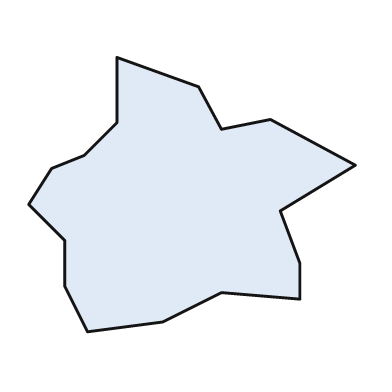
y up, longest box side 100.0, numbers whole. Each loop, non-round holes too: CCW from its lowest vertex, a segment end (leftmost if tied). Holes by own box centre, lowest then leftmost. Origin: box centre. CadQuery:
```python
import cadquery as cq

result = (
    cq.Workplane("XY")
    .moveTo(-32.0, -42.0)
    .lineTo(-9.0, -39.0)
    .lineTo(9.0, -30.0)
    .lineTo(33.0, -32.0)
    .lineTo(33.0, -21.0)
    .lineTo(27.0, -5.0)
    .lineTo(50.0, 9.0)
    .lineTo(24.0, 23.0)
    .lineTo(9.0, 20.0)
    .lineTo(2.0, 33.0)
    .lineTo(-23.0, 42.0)
    .lineTo(-23.0, 22.0)
    .lineTo(-33.0, 12.0)
    .lineTo(-43.0, 8.0)
    .lineTo(-50.0, -3.0)
    .lineTo(-39.0, -14.0)
    .lineTo(-39.0, -28.0)
    .close()
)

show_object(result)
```